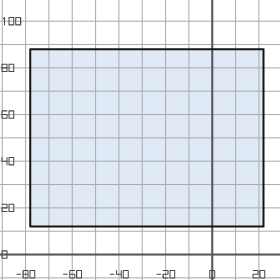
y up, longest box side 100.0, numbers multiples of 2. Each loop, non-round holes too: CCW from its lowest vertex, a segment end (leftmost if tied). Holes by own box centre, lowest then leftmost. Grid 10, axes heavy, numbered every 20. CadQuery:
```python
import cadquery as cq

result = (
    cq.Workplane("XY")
    .moveTo(-78.0, 12.0)
    .lineTo(22.0, 12.0)
    .lineTo(22.0, 88.0)
    .lineTo(-78.0, 88.0)
    .close()
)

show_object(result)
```